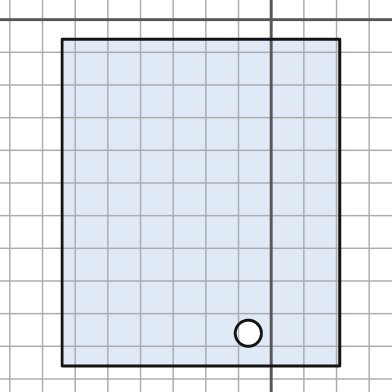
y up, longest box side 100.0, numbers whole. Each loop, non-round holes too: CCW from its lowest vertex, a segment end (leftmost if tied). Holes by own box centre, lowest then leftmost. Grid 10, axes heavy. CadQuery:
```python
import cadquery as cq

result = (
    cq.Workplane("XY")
    .moveTo(-64.0, -106.0)
    .lineTo(21.0, -106.0)
    .lineTo(21.0, -6.0)
    .lineTo(-64.0, -6.0)
    .close()
    .moveTo(-7.0, -96.0)
    .circle(4.0)
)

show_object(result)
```